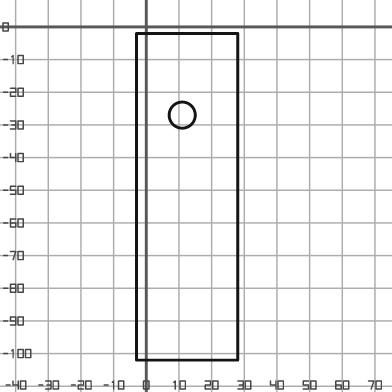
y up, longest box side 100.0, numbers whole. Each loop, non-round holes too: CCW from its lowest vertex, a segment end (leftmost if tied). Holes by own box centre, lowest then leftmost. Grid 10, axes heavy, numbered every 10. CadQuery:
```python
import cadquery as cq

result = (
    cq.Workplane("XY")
    .moveTo(-3.0, -102.0)
    .lineTo(28.0, -102.0)
    .lineTo(28.0, -2.0)
    .lineTo(-3.0, -2.0)
    .close()
    .moveTo(11.0, -27.0)
    .circle(4.0)
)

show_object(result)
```